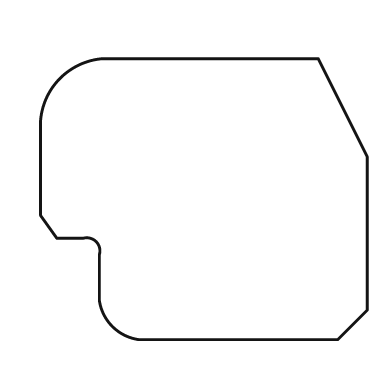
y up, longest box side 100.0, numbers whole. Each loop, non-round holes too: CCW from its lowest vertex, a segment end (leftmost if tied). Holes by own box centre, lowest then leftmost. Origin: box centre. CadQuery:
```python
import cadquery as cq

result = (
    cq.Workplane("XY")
    .moveTo(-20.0, -43.0)
    .lineTo(41.0, -43.0)
    .lineTo(50.0, -34.0)
    .lineTo(50.0, 13.0)
    .lineTo(35.0, 43.0)
    .lineTo(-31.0, 43.0)
    .threePointArc((-44.0, 37.0), (-50.0, 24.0))
    .lineTo(-50.0, -5.0)
    .lineTo(-45.0, -12.0)
    .lineTo(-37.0, -12.0)
    .threePointArc((-33.0, -13.0), (-32.0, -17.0))
    .lineTo(-32.0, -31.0)
    .threePointArc((-28.0, -39.0), (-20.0, -43.0))
    .close()
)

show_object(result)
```